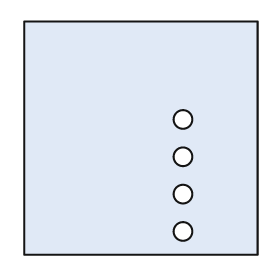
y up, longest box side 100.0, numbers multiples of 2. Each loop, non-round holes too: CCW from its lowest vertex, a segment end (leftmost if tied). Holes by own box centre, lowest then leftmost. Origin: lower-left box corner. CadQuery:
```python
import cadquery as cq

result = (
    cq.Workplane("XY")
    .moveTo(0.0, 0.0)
    .lineTo(100.0, 0.0)
    .lineTo(100.0, 100.0)
    .lineTo(0.0, 100.0)
    .close()
    .moveTo(68.0, 10.0)
    .circle(4.0)
    .moveTo(68.0, 26.0)
    .circle(4.0)
    .moveTo(68.0, 42.0)
    .circle(4.0)
    .moveTo(68.0, 58.0)
    .circle(4.0)
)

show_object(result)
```